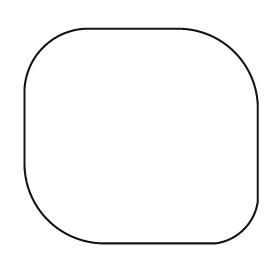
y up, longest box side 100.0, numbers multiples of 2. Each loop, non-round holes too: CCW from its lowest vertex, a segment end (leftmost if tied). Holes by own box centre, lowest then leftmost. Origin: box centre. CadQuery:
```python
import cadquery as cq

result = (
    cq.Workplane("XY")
    .moveTo(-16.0, -46.0)
    .lineTo(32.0, -46.0)
    .threePointArc((44.0, -40.0), (50.0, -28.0))
    .lineTo(50.0, 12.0)
    .threePointArc((40.0, 36.0), (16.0, 46.0))
    .lineTo(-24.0, 46.0)
    .threePointArc((-42.0, 38.0), (-50.0, 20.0))
    .lineTo(-50.0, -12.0)
    .threePointArc((-40.0, -36.0), (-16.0, -46.0))
    .close()
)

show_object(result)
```